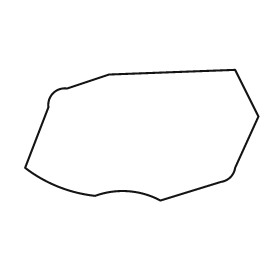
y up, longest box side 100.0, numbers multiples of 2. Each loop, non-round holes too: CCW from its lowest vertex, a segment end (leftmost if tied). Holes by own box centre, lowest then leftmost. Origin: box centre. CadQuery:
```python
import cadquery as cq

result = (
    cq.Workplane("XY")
    .moveTo(8.0, -28.0)
    .lineTo(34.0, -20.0)
    .threePointArc((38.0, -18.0), (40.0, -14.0))
    .lineTo(50.0, 8.0)
    .lineTo(40.0, 28.0)
    .lineTo(-14.0, 26.0)
    .lineTo(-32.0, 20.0)
    .threePointArc((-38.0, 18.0), (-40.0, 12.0))
    .lineTo(-50.0, -14.0)
    .threePointArc((-36.0, -22.0), (-20.0, -26.0))
    .threePointArc((-6.0, -24.0), (8.0, -28.0))
    .close()
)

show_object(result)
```